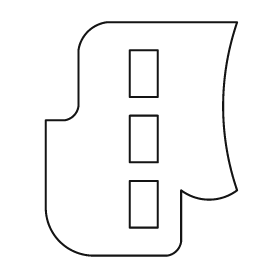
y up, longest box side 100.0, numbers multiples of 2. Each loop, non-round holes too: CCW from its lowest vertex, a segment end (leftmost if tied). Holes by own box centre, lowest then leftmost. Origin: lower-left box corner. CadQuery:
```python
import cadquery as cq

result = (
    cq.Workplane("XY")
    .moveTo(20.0, 0.0)
    .lineTo(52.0, 0.0)
    .threePointArc((56.0, 2.0), (58.0, 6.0))
    .lineTo(58.0, 28.0)
    .threePointArc((70.0, 24.0), (82.0, 28.0))
    .threePointArc((76.0, 64.0), (82.0, 100.0))
    .lineTo(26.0, 100.0)
    .threePointArc((18.0, 96.0), (14.0, 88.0))
    .lineTo(14.0, 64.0)
    .threePointArc((12.0, 60.0), (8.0, 58.0))
    .lineTo(0.0, 58.0)
    .lineTo(0.0, 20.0)
    .threePointArc((6.0, 6.0), (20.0, 0.0))
    .close()
    .moveTo(36.0, 12.0)
    .lineTo(48.0, 12.0)
    .lineTo(48.0, 32.0)
    .lineTo(36.0, 32.0)
    .close()
    .moveTo(36.0, 40.0)
    .lineTo(48.0, 40.0)
    .lineTo(48.0, 60.0)
    .lineTo(36.0, 60.0)
    .close()
    .moveTo(36.0, 68.0)
    .lineTo(48.0, 68.0)
    .lineTo(48.0, 88.0)
    .lineTo(36.0, 88.0)
    .close()
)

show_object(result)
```